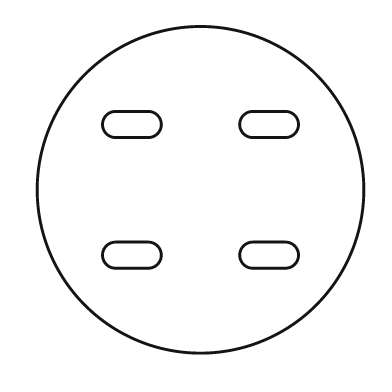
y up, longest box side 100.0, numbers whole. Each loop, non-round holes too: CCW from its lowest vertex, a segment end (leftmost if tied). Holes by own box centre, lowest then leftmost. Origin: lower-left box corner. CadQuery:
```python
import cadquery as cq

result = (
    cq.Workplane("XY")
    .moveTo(50.0, 50.0)
    .circle(50.0)
    .moveTo(24.0, 26.0)
    .lineTo(34.0, 26.0)
    .threePointArc((38.0, 30.0), (34.0, 34.0))
    .lineTo(24.0, 34.0)
    .threePointArc((20.0, 30.0), (24.0, 26.0))
    .close()
    .moveTo(66.0, 26.0)
    .lineTo(76.0, 26.0)
    .threePointArc((80.0, 30.0), (76.0, 34.0))
    .lineTo(66.0, 34.0)
    .threePointArc((62.0, 30.0), (66.0, 26.0))
    .close()
    .moveTo(24.0, 66.0)
    .lineTo(34.0, 66.0)
    .threePointArc((38.0, 70.0), (34.0, 74.0))
    .lineTo(24.0, 74.0)
    .threePointArc((20.0, 70.0), (24.0, 66.0))
    .close()
    .moveTo(66.0, 66.0)
    .lineTo(76.0, 66.0)
    .threePointArc((80.0, 70.0), (76.0, 74.0))
    .lineTo(66.0, 74.0)
    .threePointArc((62.0, 70.0), (66.0, 66.0))
    .close()
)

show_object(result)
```